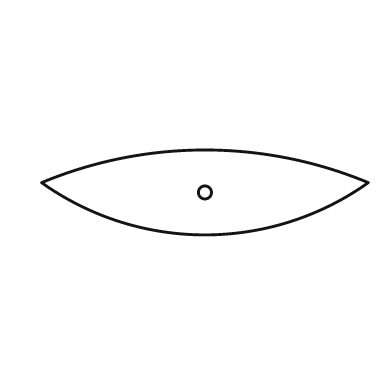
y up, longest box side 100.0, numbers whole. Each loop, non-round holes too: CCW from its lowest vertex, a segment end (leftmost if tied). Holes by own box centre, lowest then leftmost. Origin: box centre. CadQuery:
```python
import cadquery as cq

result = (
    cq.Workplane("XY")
    .moveTo(-50.0, 3.0)
    .threePointArc((0.0, -13.0), (50.0, 3.0))
    .threePointArc((0.0, 13.0), (-50.0, 3.0))
    .close()
    .moveTo(0.0, 0.0)
    .circle(2.0)
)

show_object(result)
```